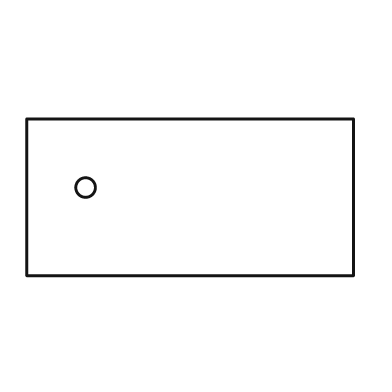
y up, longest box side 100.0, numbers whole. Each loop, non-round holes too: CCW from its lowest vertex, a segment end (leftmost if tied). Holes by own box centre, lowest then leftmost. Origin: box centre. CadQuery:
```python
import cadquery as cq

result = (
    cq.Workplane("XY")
    .moveTo(-50.0, -24.0)
    .lineTo(50.0, -24.0)
    .lineTo(50.0, 24.0)
    .lineTo(-50.0, 24.0)
    .close()
    .moveTo(-32.0, 3.0)
    .circle(3.0)
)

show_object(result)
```